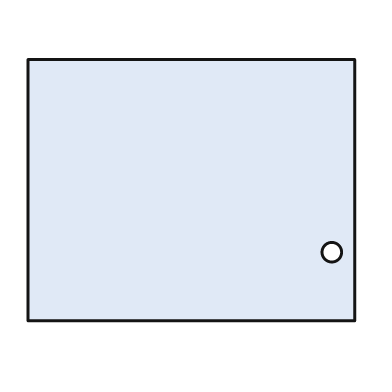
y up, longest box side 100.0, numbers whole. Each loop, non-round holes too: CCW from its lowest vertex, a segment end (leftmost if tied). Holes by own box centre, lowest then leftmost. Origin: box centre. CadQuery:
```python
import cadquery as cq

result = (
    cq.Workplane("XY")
    .moveTo(-50.0, -40.0)
    .lineTo(50.0, -40.0)
    .lineTo(50.0, 40.0)
    .lineTo(-50.0, 40.0)
    .close()
    .moveTo(43.0, -19.0)
    .circle(3.0)
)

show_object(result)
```